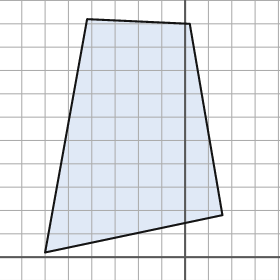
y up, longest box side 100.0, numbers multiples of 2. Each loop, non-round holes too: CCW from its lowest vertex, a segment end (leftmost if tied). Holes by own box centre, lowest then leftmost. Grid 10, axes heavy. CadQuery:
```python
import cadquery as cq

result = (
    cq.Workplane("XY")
    .moveTo(-60.0, 2.0)
    .lineTo(16.0, 18.0)
    .lineTo(2.0, 100.0)
    .lineTo(-42.0, 102.0)
    .close()
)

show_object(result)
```